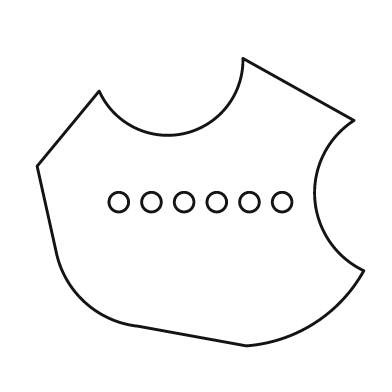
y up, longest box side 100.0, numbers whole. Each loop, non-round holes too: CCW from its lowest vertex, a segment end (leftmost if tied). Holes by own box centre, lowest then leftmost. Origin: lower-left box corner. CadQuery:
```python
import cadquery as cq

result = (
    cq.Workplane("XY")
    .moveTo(64.0, 0.0)
    .threePointArc((85.0, 7.0), (100.0, 23.0))
    .threePointArc((85.0, 45.0), (97.0, 69.0))
    .lineTo(63.0, 88.0)
    .threePointArc((45.0, 65.0), (19.0, 78.0))
    .lineTo(0.0, 55.0)
    .lineTo(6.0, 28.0)
    .threePointArc((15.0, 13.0), (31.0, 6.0))
    .close()
    .moveTo(25.0, 44.0)
    .circle(3.0)
    .moveTo(35.0, 44.0)
    .circle(3.0)
    .moveTo(45.0, 44.0)
    .circle(3.0)
    .moveTo(55.0, 44.0)
    .circle(3.0)
    .moveTo(65.0, 44.0)
    .circle(3.0)
    .moveTo(75.0, 44.0)
    .circle(3.0)
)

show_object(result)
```